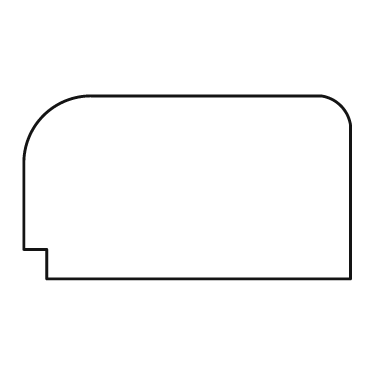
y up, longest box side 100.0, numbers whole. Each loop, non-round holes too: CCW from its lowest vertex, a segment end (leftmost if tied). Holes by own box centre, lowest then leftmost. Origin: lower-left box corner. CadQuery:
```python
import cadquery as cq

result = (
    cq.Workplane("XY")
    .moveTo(7.0, 0.0)
    .lineTo(100.0, 0.0)
    .lineTo(100.0, 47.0)
    .threePointArc((97.0, 53.0), (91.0, 56.0))
    .lineTo(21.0, 56.0)
    .threePointArc((6.0, 50.0), (0.0, 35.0))
    .lineTo(0.0, 9.0)
    .lineTo(7.0, 9.0)
    .close()
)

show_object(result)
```